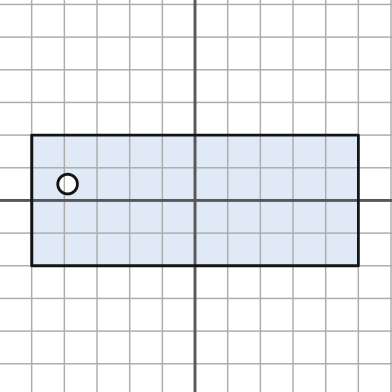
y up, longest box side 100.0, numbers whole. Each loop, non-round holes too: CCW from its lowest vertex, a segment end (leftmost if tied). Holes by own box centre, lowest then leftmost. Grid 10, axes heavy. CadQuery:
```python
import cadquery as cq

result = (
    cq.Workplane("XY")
    .moveTo(-50.0, -20.0)
    .lineTo(50.0, -20.0)
    .lineTo(50.0, 20.0)
    .lineTo(-50.0, 20.0)
    .close()
    .moveTo(-39.0, 5.0)
    .circle(3.0)
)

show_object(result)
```